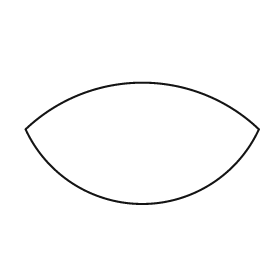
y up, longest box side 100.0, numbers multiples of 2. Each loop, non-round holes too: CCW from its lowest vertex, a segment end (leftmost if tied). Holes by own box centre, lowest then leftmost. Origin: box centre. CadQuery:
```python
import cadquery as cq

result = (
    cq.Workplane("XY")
    .moveTo(-50.0, 6.0)
    .threePointArc((0.0, -26.0), (50.0, 6.0))
    .threePointArc((0.0, 26.0), (-50.0, 6.0))
    .close()
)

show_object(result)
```